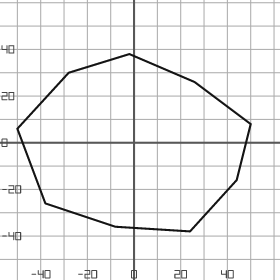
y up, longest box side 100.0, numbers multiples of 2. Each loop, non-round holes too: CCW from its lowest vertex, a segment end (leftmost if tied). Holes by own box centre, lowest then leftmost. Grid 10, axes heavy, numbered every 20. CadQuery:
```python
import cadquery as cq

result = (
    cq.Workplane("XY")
    .moveTo(24.0, -38.0)
    .lineTo(44.0, -16.0)
    .lineTo(50.0, 8.0)
    .lineTo(26.0, 26.0)
    .lineTo(-2.0, 38.0)
    .lineTo(-28.0, 30.0)
    .lineTo(-50.0, 6.0)
    .lineTo(-38.0, -26.0)
    .lineTo(-8.0, -36.0)
    .close()
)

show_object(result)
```